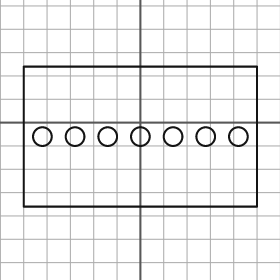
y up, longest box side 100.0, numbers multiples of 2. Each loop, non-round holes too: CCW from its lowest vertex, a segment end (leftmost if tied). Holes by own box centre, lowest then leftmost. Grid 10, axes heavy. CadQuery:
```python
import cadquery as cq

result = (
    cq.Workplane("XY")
    .moveTo(-50.0, -36.0)
    .lineTo(50.0, -36.0)
    .lineTo(50.0, 24.0)
    .lineTo(-50.0, 24.0)
    .close()
    .moveTo(-42.0, -6.0)
    .circle(4.0)
    .moveTo(-28.0, -6.0)
    .circle(4.0)
    .moveTo(-14.0, -6.0)
    .circle(4.0)
    .moveTo(0.0, -6.0)
    .circle(4.0)
    .moveTo(14.0, -6.0)
    .circle(4.0)
    .moveTo(28.0, -6.0)
    .circle(4.0)
    .moveTo(42.0, -6.0)
    .circle(4.0)
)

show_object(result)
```